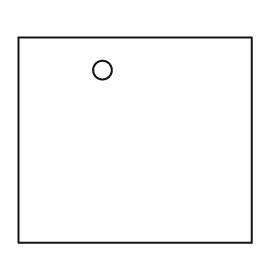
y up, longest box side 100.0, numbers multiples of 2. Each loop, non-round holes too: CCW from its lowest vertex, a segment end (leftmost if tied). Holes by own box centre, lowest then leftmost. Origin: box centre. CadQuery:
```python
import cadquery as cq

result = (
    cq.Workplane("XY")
    .moveTo(-50.0, -44.0)
    .lineTo(50.0, -44.0)
    .lineTo(50.0, 44.0)
    .lineTo(-50.0, 44.0)
    .close()
    .moveTo(-14.0, 30.0)
    .circle(4.0)
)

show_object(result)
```